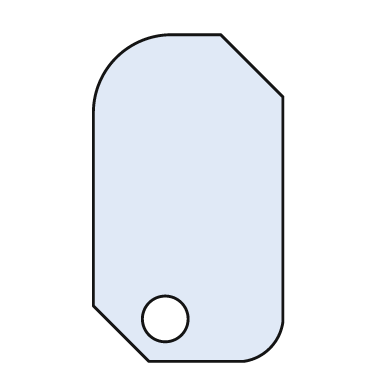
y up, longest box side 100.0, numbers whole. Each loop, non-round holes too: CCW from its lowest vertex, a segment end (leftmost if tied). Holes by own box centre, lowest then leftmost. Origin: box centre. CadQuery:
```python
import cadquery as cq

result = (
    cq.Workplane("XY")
    .moveTo(-12.0, -50.0)
    .lineTo(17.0, -50.0)
    .threePointArc((25.0, -46.0), (29.0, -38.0))
    .lineTo(29.0, 31.0)
    .lineTo(10.0, 50.0)
    .lineTo(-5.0, 50.0)
    .threePointArc((-22.0, 43.0), (-29.0, 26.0))
    .lineTo(-29.0, -33.0)
    .close()
    .moveTo(-7.0, -37.0)
    .circle(7.0)
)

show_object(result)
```